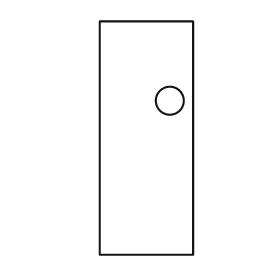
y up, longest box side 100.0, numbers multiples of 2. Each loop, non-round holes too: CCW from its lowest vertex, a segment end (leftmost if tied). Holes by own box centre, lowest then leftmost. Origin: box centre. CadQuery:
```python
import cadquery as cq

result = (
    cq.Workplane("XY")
    .moveTo(-20.0, -50.0)
    .lineTo(20.0, -50.0)
    .lineTo(20.0, 50.0)
    .lineTo(-20.0, 50.0)
    .close()
    .moveTo(10.0, 16.0)
    .circle(6.0)
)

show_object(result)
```